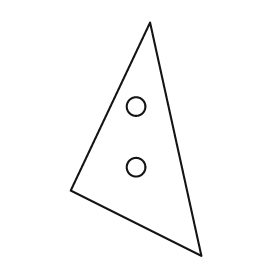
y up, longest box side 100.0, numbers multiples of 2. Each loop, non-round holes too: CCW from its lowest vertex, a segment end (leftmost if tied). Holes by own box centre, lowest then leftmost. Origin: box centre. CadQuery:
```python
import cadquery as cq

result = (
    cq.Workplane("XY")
    .moveTo(28.0, -50.0)
    .lineTo(6.0, 50.0)
    .lineTo(-28.0, -22.0)
    .close()
    .moveTo(0.0, -12.0)
    .circle(4.0)
    .moveTo(0.0, 14.0)
    .circle(4.0)
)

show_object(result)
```